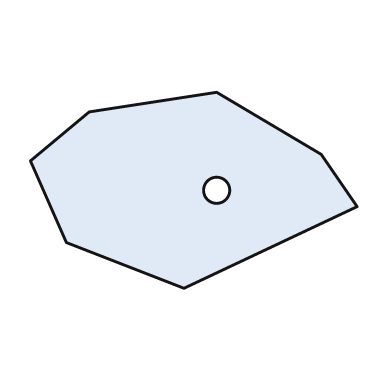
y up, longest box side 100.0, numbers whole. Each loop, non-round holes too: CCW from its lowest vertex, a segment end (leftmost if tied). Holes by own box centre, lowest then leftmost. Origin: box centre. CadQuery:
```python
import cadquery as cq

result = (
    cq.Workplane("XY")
    .moveTo(-3.0, -30.0)
    .lineTo(50.0, -5.0)
    .lineTo(39.0, 11.0)
    .lineTo(7.0, 30.0)
    .lineTo(-32.0, 24.0)
    .lineTo(-50.0, 9.0)
    .lineTo(-39.0, -16.0)
    .close()
    .moveTo(7.0, 0.0)
    .circle(4.0)
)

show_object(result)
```